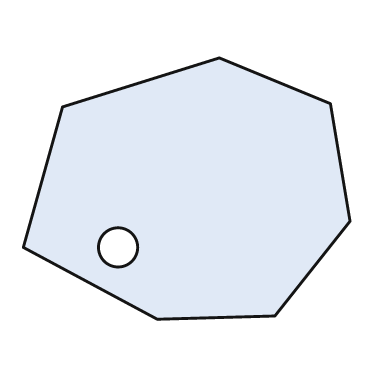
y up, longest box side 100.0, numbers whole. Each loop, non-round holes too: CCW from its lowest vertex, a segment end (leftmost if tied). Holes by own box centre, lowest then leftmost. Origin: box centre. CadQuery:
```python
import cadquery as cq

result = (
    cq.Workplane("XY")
    .moveTo(-9.0, -40.0)
    .lineTo(27.0, -39.0)
    .lineTo(50.0, -10.0)
    .lineTo(44.0, 26.0)
    .lineTo(10.0, 40.0)
    .lineTo(-38.0, 25.0)
    .lineTo(-50.0, -18.0)
    .close()
    .moveTo(-21.0, -18.0)
    .circle(6.0)
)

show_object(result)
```